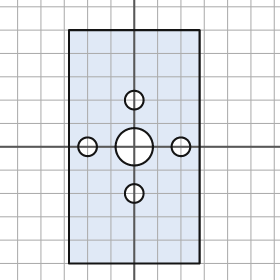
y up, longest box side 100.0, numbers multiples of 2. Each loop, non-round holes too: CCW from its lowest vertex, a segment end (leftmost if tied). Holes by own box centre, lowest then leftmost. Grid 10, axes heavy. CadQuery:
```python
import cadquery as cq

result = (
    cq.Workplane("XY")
    .moveTo(-28.0, -50.0)
    .lineTo(28.0, -50.0)
    .lineTo(28.0, 50.0)
    .lineTo(-28.0, 50.0)
    .close()
    .moveTo(0.0, -20.0)
    .circle(4.0)
    .moveTo(-20.0, 0.0)
    .circle(4.0)
    .moveTo(0.0, 0.0)
    .circle(8.0)
    .moveTo(20.0, 0.0)
    .circle(4.0)
    .moveTo(0.0, 20.0)
    .circle(4.0)
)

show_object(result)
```